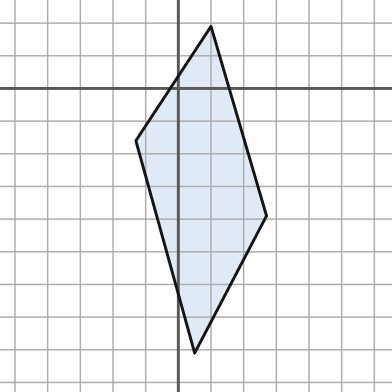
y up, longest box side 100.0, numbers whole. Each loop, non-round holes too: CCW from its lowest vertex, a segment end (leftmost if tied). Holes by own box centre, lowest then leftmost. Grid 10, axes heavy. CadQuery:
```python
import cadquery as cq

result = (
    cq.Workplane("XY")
    .moveTo(5.0, -81.0)
    .lineTo(27.0, -39.0)
    .lineTo(10.0, 19.0)
    .lineTo(-13.0, -16.0)
    .close()
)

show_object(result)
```